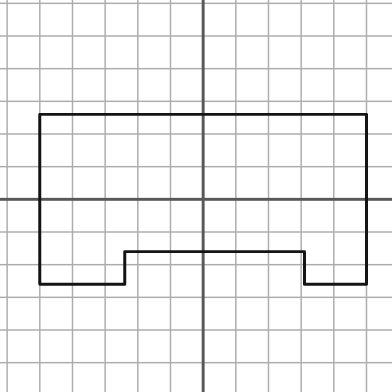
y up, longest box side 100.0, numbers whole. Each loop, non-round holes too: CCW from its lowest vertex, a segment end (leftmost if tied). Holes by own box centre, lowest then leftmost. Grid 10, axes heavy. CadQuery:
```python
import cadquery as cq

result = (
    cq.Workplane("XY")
    .moveTo(-50.0, -26.0)
    .lineTo(-24.0, -26.0)
    .lineTo(-24.0, -16.0)
    .lineTo(31.0, -16.0)
    .lineTo(31.0, -26.0)
    .lineTo(50.0, -26.0)
    .lineTo(50.0, 26.0)
    .lineTo(-50.0, 26.0)
    .close()
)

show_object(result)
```